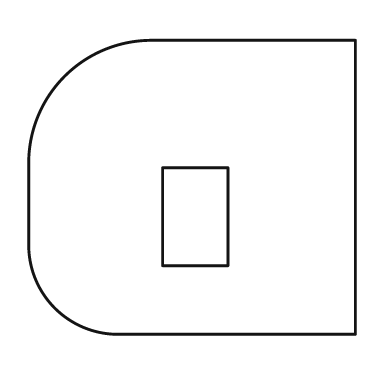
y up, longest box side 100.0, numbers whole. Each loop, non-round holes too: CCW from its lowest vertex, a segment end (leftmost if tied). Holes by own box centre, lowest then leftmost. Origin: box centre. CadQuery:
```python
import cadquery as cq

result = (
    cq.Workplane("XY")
    .moveTo(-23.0, -45.0)
    .lineTo(50.0, -45.0)
    .lineTo(50.0, 45.0)
    .lineTo(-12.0, 45.0)
    .threePointArc((-39.0, 34.0), (-50.0, 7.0))
    .lineTo(-50.0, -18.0)
    .threePointArc((-42.0, -37.0), (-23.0, -45.0))
    .close()
    .moveTo(-9.0, -24.0)
    .lineTo(11.0, -24.0)
    .lineTo(11.0, 6.0)
    .lineTo(-9.0, 6.0)
    .close()
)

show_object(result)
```